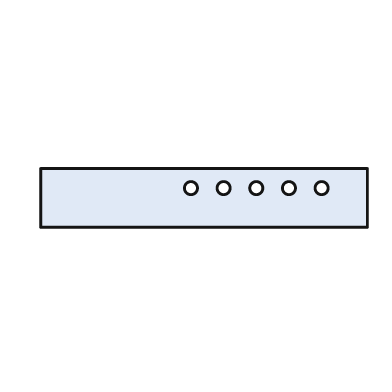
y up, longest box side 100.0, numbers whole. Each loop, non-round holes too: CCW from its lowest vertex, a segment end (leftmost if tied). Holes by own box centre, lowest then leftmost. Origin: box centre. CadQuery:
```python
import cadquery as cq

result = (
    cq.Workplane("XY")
    .moveTo(-50.0, -9.0)
    .lineTo(50.0, -9.0)
    .lineTo(50.0, 9.0)
    .lineTo(-50.0, 9.0)
    .close()
    .moveTo(-4.0, 3.0)
    .circle(2.0)
    .moveTo(6.0, 3.0)
    .circle(2.0)
    .moveTo(16.0, 3.0)
    .circle(2.0)
    .moveTo(26.0, 3.0)
    .circle(2.0)
    .moveTo(36.0, 3.0)
    .circle(2.0)
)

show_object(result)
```